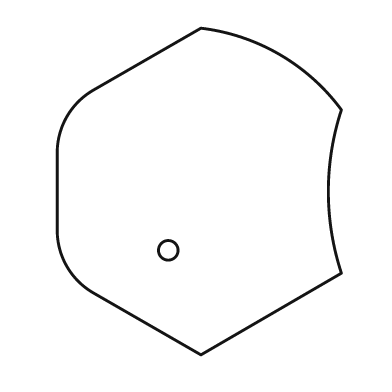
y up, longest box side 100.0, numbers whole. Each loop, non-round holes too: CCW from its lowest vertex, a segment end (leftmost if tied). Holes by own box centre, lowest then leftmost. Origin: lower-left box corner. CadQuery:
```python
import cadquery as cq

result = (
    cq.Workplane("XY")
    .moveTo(44.0, 0.0)
    .lineTo(87.0, 25.0)
    .threePointArc((83.0, 50.0), (87.0, 75.0))
    .threePointArc((68.0, 92.0), (44.0, 100.0))
    .lineTo(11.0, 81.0)
    .threePointArc((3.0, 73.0), (0.0, 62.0))
    .lineTo(0.0, 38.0)
    .threePointArc((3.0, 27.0), (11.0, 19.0))
    .close()
    .moveTo(34.0, 32.0)
    .circle(3.0)
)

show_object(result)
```